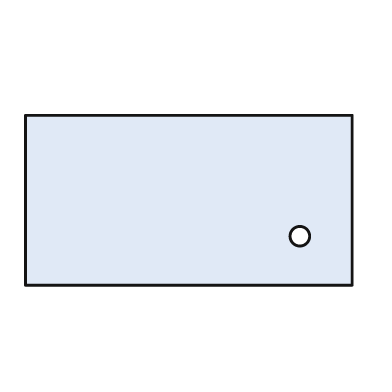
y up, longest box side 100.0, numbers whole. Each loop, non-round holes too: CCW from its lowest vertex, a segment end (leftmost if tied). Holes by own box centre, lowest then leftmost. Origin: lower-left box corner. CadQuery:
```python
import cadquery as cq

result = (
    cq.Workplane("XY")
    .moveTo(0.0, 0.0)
    .lineTo(100.0, 0.0)
    .lineTo(100.0, 52.0)
    .lineTo(0.0, 52.0)
    .close()
    .moveTo(84.0, 15.0)
    .circle(3.0)
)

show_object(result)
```